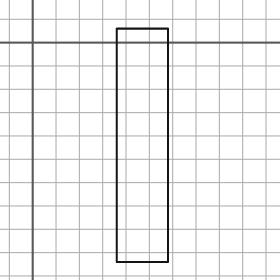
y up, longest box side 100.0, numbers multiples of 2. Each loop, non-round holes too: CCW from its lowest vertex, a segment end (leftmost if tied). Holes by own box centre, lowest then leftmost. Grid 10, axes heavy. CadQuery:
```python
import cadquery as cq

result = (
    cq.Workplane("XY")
    .moveTo(36.0, -94.0)
    .lineTo(58.0, -94.0)
    .lineTo(58.0, 6.0)
    .lineTo(36.0, 6.0)
    .close()
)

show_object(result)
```